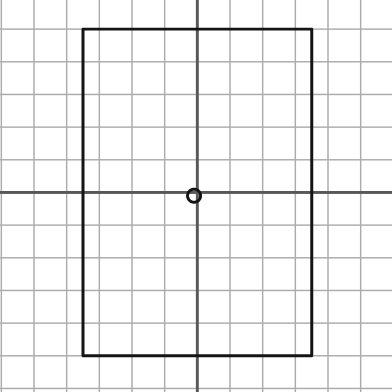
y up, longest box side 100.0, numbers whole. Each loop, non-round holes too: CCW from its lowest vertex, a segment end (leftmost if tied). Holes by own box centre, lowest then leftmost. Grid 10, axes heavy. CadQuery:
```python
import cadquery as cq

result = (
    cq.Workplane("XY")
    .moveTo(-35.0, -50.0)
    .lineTo(35.0, -50.0)
    .lineTo(35.0, 50.0)
    .lineTo(-35.0, 50.0)
    .close()
    .moveTo(-1.0, -1.0)
    .circle(2.0)
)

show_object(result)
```